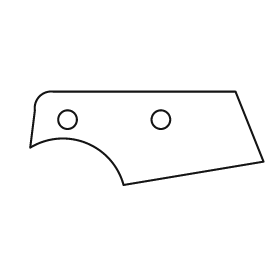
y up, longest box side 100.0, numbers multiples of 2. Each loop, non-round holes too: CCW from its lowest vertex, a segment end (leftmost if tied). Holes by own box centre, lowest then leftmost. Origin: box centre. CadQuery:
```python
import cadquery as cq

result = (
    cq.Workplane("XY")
    .moveTo(-10.0, -20.0)
    .lineTo(50.0, -10.0)
    .lineTo(38.0, 20.0)
    .lineTo(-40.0, 20.0)
    .threePointArc((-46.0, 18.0), (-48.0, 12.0))
    .lineTo(-50.0, -4.0)
    .threePointArc((-26.0, -2.0), (-10.0, -20.0))
    .close()
    .moveTo(-34.0, 8.0)
    .circle(4.0)
    .moveTo(6.0, 8.0)
    .circle(4.0)
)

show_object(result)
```